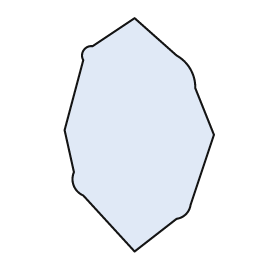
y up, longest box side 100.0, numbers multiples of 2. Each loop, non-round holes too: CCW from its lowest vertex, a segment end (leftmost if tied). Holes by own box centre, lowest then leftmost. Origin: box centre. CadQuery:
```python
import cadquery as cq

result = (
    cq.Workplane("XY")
    .moveTo(-2.0, -50.0)
    .lineTo(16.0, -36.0)
    .threePointArc((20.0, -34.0), (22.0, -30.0))
    .lineTo(32.0, 0.0)
    .lineTo(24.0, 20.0)
    .threePointArc((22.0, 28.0), (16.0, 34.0))
    .lineTo(-2.0, 50.0)
    .lineTo(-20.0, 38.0)
    .threePointArc((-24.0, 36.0), (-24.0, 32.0))
    .lineTo(-32.0, 2.0)
    .lineTo(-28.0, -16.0)
    .threePointArc((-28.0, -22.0), (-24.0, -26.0))
    .close()
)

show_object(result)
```